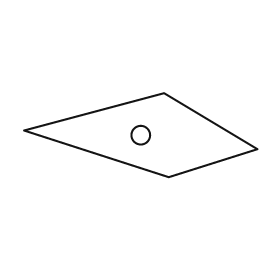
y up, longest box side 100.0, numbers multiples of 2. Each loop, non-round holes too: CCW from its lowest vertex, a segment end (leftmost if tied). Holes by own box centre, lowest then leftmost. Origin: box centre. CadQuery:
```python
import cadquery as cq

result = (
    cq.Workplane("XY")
    .moveTo(12.0, -18.0)
    .lineTo(50.0, -6.0)
    .lineTo(10.0, 18.0)
    .lineTo(-50.0, 2.0)
    .close()
    .moveTo(0.0, 0.0)
    .circle(4.0)
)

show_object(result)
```